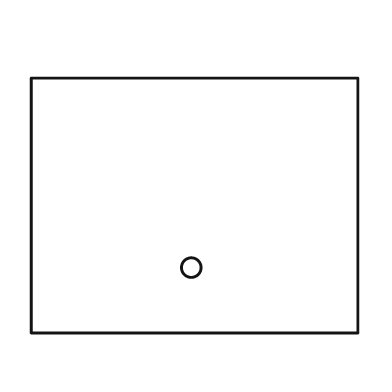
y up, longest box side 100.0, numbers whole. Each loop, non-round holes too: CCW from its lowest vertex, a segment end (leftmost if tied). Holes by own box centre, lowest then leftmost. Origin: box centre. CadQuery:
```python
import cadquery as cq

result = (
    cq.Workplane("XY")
    .moveTo(-50.0, -39.0)
    .lineTo(50.0, -39.0)
    .lineTo(50.0, 39.0)
    .lineTo(-50.0, 39.0)
    .close()
    .moveTo(-1.0, -19.0)
    .circle(3.0)
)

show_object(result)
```